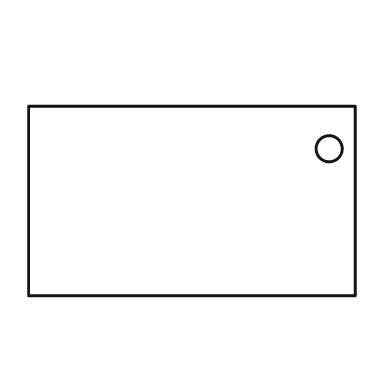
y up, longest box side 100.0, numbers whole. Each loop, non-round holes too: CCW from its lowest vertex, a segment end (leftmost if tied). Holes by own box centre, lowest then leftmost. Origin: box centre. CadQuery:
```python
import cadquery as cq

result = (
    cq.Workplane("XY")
    .moveTo(-50.0, -29.0)
    .lineTo(50.0, -29.0)
    .lineTo(50.0, 29.0)
    .lineTo(-50.0, 29.0)
    .close()
    .moveTo(42.0, 16.0)
    .circle(4.0)
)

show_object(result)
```